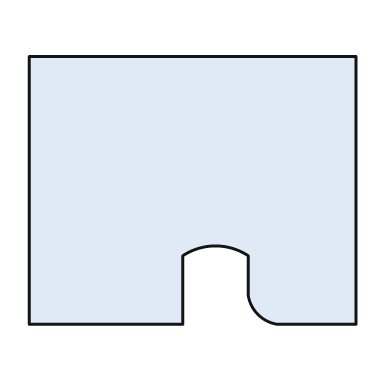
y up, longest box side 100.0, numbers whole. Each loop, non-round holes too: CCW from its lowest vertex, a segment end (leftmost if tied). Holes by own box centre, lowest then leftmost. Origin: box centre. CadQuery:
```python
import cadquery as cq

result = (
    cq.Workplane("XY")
    .moveTo(-50.0, -41.0)
    .lineTo(-3.0, -41.0)
    .lineTo(-3.0, -20.0)
    .threePointArc((7.0, -17.0), (17.0, -20.0))
    .lineTo(17.0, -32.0)
    .threePointArc((20.0, -38.0), (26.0, -41.0))
    .lineTo(50.0, -41.0)
    .lineTo(50.0, 41.0)
    .lineTo(-50.0, 41.0)
    .close()
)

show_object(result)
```